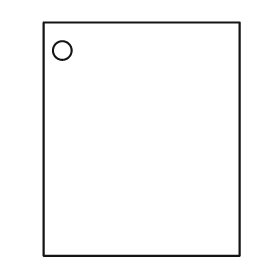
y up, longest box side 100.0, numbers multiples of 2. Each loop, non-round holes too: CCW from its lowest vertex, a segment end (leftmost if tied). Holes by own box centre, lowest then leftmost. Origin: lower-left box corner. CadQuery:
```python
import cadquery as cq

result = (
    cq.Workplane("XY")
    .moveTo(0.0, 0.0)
    .lineTo(84.0, 0.0)
    .lineTo(84.0, 100.0)
    .lineTo(0.0, 100.0)
    .close()
    .moveTo(8.0, 88.0)
    .circle(4.0)
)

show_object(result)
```